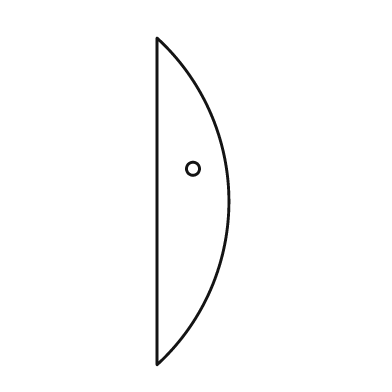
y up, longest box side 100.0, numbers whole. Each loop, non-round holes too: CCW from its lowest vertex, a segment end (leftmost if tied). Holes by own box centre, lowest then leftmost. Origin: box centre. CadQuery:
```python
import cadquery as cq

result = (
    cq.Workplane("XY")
    .moveTo(-11.0, -50.0)
    .threePointArc((11.0, 0.0), (-11.0, 50.0))
    .close()
    .moveTo(0.0, 10.0)
    .circle(2.0)
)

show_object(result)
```